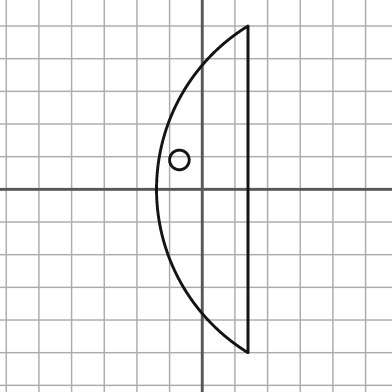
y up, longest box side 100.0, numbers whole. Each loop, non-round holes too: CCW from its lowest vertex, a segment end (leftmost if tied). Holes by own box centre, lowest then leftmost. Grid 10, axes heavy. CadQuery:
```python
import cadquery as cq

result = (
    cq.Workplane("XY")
    .moveTo(14.0, -50.0)
    .lineTo(14.0, 50.0)
    .threePointArc((-14.0, 0.0), (14.0, -50.0))
    .close()
    .moveTo(-7.0, 9.0)
    .circle(3.0)
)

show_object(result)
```